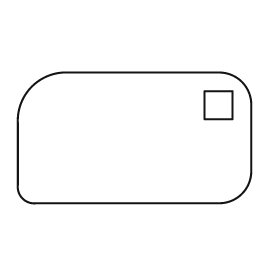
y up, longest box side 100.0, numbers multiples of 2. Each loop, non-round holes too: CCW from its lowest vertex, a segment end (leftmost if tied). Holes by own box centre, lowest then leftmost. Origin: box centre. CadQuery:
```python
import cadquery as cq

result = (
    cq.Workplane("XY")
    .moveTo(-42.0, -28.0)
    .lineTo(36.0, -28.0)
    .threePointArc((46.0, -24.0), (50.0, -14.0))
    .lineTo(50.0, 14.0)
    .threePointArc((46.0, 24.0), (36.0, 28.0))
    .lineTo(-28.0, 28.0)
    .threePointArc((-44.0, 22.0), (-50.0, 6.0))
    .lineTo(-50.0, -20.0)
    .threePointArc((-48.0, -26.0), (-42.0, -28.0))
    .close()
    .moveTo(30.0, 8.0)
    .lineTo(42.0, 8.0)
    .lineTo(42.0, 20.0)
    .lineTo(30.0, 20.0)
    .close()
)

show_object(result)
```